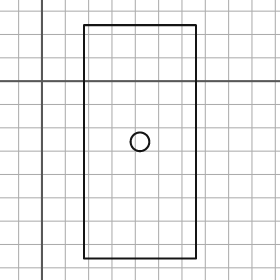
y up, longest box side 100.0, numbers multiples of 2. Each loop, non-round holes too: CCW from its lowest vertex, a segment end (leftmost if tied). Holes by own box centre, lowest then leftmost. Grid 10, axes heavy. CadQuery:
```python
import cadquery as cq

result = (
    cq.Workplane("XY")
    .moveTo(18.0, -76.0)
    .lineTo(66.0, -76.0)
    .lineTo(66.0, 24.0)
    .lineTo(18.0, 24.0)
    .close()
    .moveTo(42.0, -26.0)
    .circle(4.0)
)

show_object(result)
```